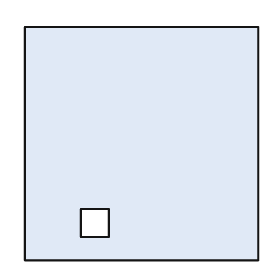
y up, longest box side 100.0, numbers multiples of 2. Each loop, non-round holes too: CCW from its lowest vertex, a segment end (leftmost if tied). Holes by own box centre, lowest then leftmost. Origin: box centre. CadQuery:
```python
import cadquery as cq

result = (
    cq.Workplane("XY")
    .moveTo(-50.0, -50.0)
    .lineTo(50.0, -50.0)
    .lineTo(50.0, 50.0)
    .lineTo(-50.0, 50.0)
    .close()
    .moveTo(-26.0, -40.0)
    .lineTo(-14.0, -40.0)
    .lineTo(-14.0, -28.0)
    .lineTo(-26.0, -28.0)
    .close()
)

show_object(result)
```